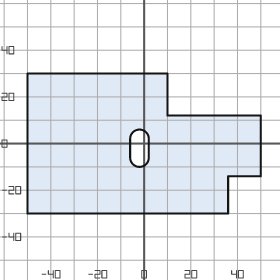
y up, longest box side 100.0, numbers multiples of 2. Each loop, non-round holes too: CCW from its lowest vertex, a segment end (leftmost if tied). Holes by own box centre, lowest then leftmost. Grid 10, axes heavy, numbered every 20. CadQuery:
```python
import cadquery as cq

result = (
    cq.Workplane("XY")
    .moveTo(-50.0, -30.0)
    .lineTo(36.0, -30.0)
    .lineTo(36.0, -14.0)
    .lineTo(50.0, -14.0)
    .lineTo(50.0, 12.0)
    .lineTo(10.0, 12.0)
    .lineTo(10.0, 30.0)
    .lineTo(-50.0, 30.0)
    .close()
    .moveTo(-6.0, -6.0)
    .threePointArc((-2.0, -10.0), (2.0, -6.0))
    .lineTo(2.0, 2.0)
    .threePointArc((-2.0, 6.0), (-6.0, 2.0))
    .close()
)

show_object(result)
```